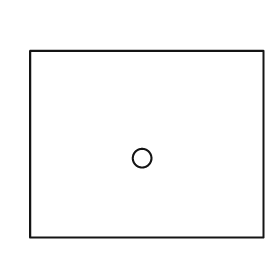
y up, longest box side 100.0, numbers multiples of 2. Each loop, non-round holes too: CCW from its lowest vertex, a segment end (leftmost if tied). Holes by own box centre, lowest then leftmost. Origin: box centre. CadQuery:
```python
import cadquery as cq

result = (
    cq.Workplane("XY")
    .moveTo(-50.0, -40.0)
    .lineTo(50.0, -40.0)
    .lineTo(50.0, 40.0)
    .lineTo(-50.0, 40.0)
    .close()
    .moveTo(-2.0, -6.0)
    .circle(4.0)
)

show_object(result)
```